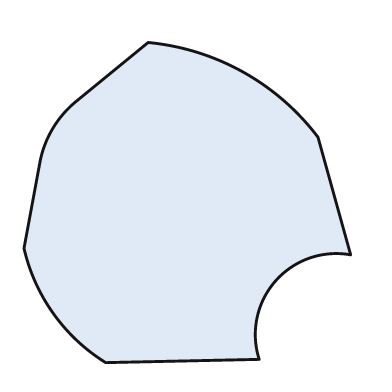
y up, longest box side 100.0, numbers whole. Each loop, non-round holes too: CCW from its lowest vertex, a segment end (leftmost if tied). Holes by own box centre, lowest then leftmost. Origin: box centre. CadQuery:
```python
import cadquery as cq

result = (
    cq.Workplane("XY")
    .moveTo(-25.0, -49.0)
    .lineTo(22.0, -48.0)
    .threePointArc((27.0, -24.0), (50.0, -16.0))
    .lineTo(40.0, 20.0)
    .threePointArc((17.0, 40.0), (-12.0, 49.0))
    .lineTo(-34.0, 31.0)
    .threePointArc((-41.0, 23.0), (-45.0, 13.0))
    .lineTo(-50.0, -14.0)
    .threePointArc((-41.0, -34.0), (-25.0, -49.0))
    .close()
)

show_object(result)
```